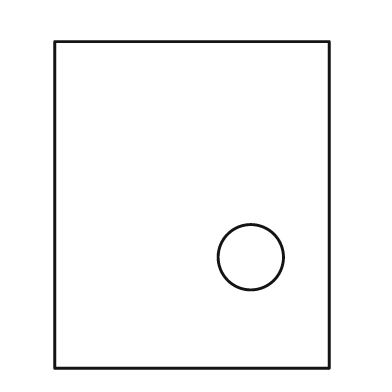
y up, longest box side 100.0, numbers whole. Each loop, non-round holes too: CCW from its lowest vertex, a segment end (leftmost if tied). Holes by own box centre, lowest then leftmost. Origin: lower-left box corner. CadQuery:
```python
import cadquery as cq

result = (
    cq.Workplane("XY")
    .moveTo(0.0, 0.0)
    .lineTo(84.0, 0.0)
    .lineTo(84.0, 100.0)
    .lineTo(0.0, 100.0)
    .close()
    .moveTo(60.0, 34.0)
    .circle(10.0)
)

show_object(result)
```